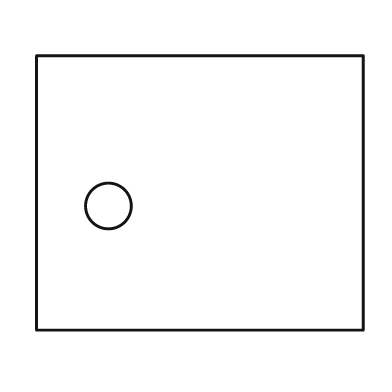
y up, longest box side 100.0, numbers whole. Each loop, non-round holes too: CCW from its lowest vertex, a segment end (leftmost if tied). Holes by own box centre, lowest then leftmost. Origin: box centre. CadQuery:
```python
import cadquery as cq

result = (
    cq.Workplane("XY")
    .moveTo(-50.0, -42.0)
    .lineTo(50.0, -42.0)
    .lineTo(50.0, 42.0)
    .lineTo(-50.0, 42.0)
    .close()
    .moveTo(-28.0, -4.0)
    .circle(7.0)
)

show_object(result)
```